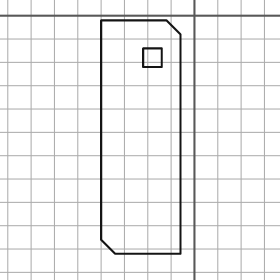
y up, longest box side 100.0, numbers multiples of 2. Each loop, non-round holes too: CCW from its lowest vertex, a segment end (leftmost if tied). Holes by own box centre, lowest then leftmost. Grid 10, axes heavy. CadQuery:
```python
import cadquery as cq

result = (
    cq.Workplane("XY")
    .moveTo(-34.0, -102.0)
    .lineTo(-6.0, -102.0)
    .lineTo(-6.0, -8.0)
    .lineTo(-12.0, -2.0)
    .lineTo(-40.0, -2.0)
    .lineTo(-40.0, -96.0)
    .close()
    .moveTo(-22.0, -22.0)
    .lineTo(-14.0, -22.0)
    .lineTo(-14.0, -14.0)
    .lineTo(-22.0, -14.0)
    .close()
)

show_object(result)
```